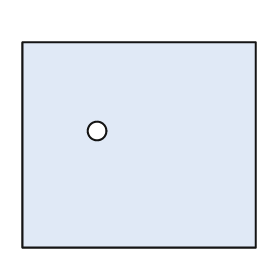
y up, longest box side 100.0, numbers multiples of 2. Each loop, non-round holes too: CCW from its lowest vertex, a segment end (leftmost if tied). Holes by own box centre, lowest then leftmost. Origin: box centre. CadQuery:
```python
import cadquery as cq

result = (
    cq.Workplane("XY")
    .moveTo(-50.0, -44.0)
    .lineTo(50.0, -44.0)
    .lineTo(50.0, 44.0)
    .lineTo(-50.0, 44.0)
    .close()
    .moveTo(-18.0, 6.0)
    .circle(4.0)
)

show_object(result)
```